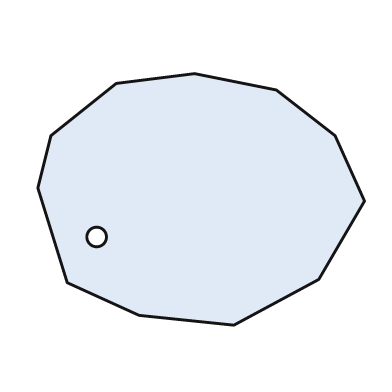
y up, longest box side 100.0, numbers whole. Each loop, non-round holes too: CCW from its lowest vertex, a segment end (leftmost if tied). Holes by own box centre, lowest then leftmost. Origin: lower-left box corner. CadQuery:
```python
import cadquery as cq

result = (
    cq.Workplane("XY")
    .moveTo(60.0, 0.0)
    .lineTo(86.0, 14.0)
    .lineTo(100.0, 38.0)
    .lineTo(91.0, 58.0)
    .lineTo(73.0, 72.0)
    .lineTo(48.0, 77.0)
    .lineTo(24.0, 74.0)
    .lineTo(4.0, 58.0)
    .lineTo(0.0, 42.0)
    .lineTo(9.0, 13.0)
    .lineTo(31.0, 3.0)
    .close()
    .moveTo(18.0, 27.0)
    .circle(3.0)
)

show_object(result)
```